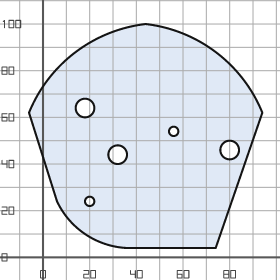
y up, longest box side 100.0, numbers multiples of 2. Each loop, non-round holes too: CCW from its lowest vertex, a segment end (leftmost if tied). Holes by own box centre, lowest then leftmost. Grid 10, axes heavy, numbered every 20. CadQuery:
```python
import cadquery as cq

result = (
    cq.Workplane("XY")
    .moveTo(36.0, 4.0)
    .lineTo(74.0, 4.0)
    .lineTo(94.0, 62.0)
    .threePointArc((74.0, 88.0), (44.0, 100.0))
    .threePointArc((14.0, 88.0), (-6.0, 62.0))
    .lineTo(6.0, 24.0)
    .threePointArc((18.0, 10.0), (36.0, 4.0))
    .close()
    .moveTo(20.0, 24.0)
    .circle(2.0)
    .moveTo(32.0, 44.0)
    .circle(4.0)
    .moveTo(80.0, 46.0)
    .circle(4.0)
    .moveTo(56.0, 54.0)
    .circle(2.0)
    .moveTo(18.0, 64.0)
    .circle(4.0)
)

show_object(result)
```